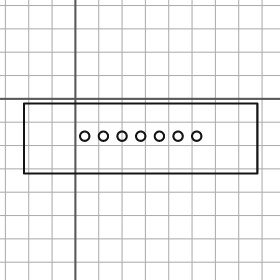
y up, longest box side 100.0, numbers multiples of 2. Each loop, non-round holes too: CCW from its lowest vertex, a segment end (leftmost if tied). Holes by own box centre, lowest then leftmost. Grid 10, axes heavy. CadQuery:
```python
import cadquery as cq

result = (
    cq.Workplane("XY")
    .moveTo(-22.0, -32.0)
    .lineTo(78.0, -32.0)
    .lineTo(78.0, -2.0)
    .lineTo(-22.0, -2.0)
    .close()
    .moveTo(4.0, -16.0)
    .circle(2.0)
    .moveTo(12.0, -16.0)
    .circle(2.0)
    .moveTo(20.0, -16.0)
    .circle(2.0)
    .moveTo(28.0, -16.0)
    .circle(2.0)
    .moveTo(36.0, -16.0)
    .circle(2.0)
    .moveTo(44.0, -16.0)
    .circle(2.0)
    .moveTo(52.0, -16.0)
    .circle(2.0)
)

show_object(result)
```